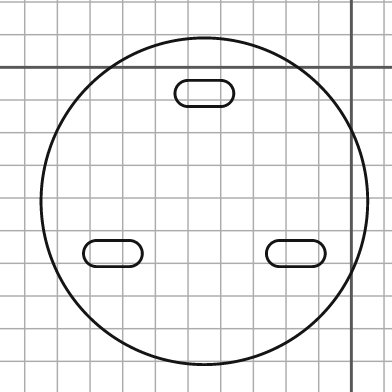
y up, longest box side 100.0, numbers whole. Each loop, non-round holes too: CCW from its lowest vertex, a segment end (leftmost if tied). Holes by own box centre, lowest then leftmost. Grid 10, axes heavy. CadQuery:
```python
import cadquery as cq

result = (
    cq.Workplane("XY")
    .moveTo(-45.0, -41.0)
    .circle(50.0)
    .moveTo(-78.0, -61.0)
    .lineTo(-68.0, -61.0)
    .threePointArc((-64.0, -57.0), (-68.0, -53.0))
    .lineTo(-78.0, -53.0)
    .threePointArc((-82.0, -57.0), (-78.0, -61.0))
    .close()
    .moveTo(-22.0, -61.0)
    .lineTo(-12.0, -61.0)
    .threePointArc((-8.0, -57.0), (-12.0, -53.0))
    .lineTo(-22.0, -53.0)
    .threePointArc((-26.0, -57.0), (-22.0, -61.0))
    .close()
    .moveTo(-50.0, -12.0)
    .lineTo(-40.0, -12.0)
    .threePointArc((-36.0, -8.0), (-40.0, -4.0))
    .lineTo(-50.0, -4.0)
    .threePointArc((-54.0, -8.0), (-50.0, -12.0))
    .close()
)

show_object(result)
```